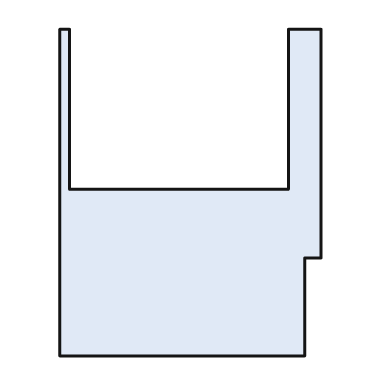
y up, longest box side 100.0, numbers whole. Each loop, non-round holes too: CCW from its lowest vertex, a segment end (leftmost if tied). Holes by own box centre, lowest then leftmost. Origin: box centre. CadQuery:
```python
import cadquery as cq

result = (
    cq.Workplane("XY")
    .moveTo(-40.0, -50.0)
    .lineTo(35.0, -50.0)
    .lineTo(35.0, -20.0)
    .lineTo(40.0, -20.0)
    .lineTo(40.0, 50.0)
    .lineTo(30.0, 50.0)
    .lineTo(30.0, 1.0)
    .lineTo(-37.0, 1.0)
    .lineTo(-37.0, 50.0)
    .lineTo(-40.0, 50.0)
    .close()
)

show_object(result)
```